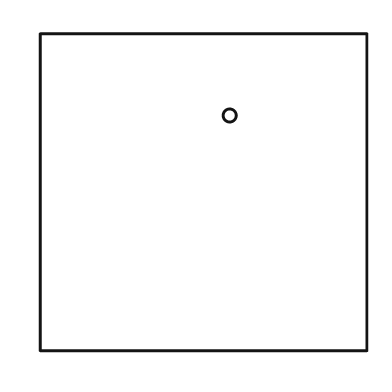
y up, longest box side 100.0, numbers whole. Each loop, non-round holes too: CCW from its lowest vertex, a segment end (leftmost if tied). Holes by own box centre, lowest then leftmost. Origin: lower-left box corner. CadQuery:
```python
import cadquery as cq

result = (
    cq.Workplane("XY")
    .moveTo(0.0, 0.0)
    .lineTo(100.0, 0.0)
    .lineTo(100.0, 97.0)
    .lineTo(0.0, 97.0)
    .close()
    .moveTo(58.0, 72.0)
    .circle(2.0)
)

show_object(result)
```